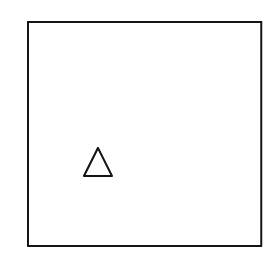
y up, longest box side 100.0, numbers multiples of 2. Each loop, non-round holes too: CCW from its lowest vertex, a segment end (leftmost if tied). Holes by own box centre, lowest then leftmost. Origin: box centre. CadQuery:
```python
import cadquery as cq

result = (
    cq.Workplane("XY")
    .moveTo(-50.0, -48.0)
    .lineTo(50.0, -48.0)
    .lineTo(50.0, 48.0)
    .lineTo(-50.0, 48.0)
    .close()
    .moveTo(-26.0, -18.0)
    .lineTo(-14.0, -18.0)
    .lineTo(-20.0, -6.0)
    .close()
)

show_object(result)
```